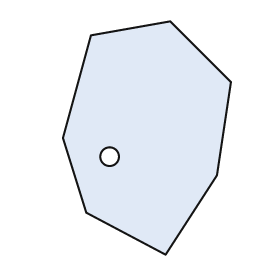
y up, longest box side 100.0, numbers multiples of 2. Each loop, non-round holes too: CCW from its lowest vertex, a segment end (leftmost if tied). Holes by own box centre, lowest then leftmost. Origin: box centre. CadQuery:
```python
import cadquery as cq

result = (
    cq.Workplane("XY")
    .moveTo(8.0, -50.0)
    .lineTo(30.0, -16.0)
    .lineTo(36.0, 24.0)
    .lineTo(10.0, 50.0)
    .lineTo(-24.0, 44.0)
    .lineTo(-36.0, 0.0)
    .lineTo(-26.0, -32.0)
    .close()
    .moveTo(-16.0, -8.0)
    .circle(4.0)
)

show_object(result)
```